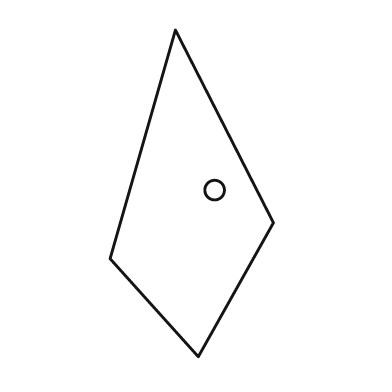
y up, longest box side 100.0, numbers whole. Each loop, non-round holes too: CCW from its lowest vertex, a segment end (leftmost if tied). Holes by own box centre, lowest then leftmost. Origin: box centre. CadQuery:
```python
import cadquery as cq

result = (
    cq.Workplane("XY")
    .moveTo(2.0, -50.0)
    .lineTo(25.0, -9.0)
    .lineTo(-5.0, 50.0)
    .lineTo(-25.0, -20.0)
    .close()
    .moveTo(7.0, 1.0)
    .circle(3.0)
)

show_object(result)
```